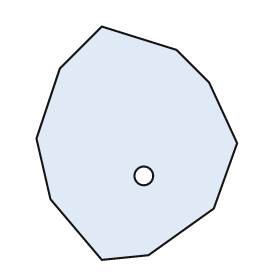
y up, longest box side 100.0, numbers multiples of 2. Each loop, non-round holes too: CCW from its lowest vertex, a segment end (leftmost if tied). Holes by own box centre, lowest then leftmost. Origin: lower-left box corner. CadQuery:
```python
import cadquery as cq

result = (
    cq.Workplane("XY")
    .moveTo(28.0, 0.0)
    .lineTo(48.0, 2.0)
    .lineTo(76.0, 22.0)
    .lineTo(86.0, 50.0)
    .lineTo(74.0, 76.0)
    .lineTo(60.0, 90.0)
    .lineTo(28.0, 100.0)
    .lineTo(10.0, 82.0)
    .lineTo(0.0, 52.0)
    .lineTo(6.0, 26.0)
    .close()
    .moveTo(46.0, 36.0)
    .circle(4.0)
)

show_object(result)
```